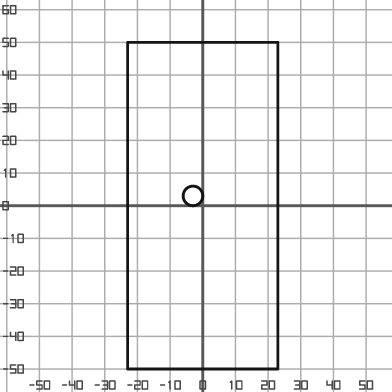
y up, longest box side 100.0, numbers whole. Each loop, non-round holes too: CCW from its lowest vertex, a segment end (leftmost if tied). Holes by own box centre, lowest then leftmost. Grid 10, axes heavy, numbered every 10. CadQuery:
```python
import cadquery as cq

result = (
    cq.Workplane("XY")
    .moveTo(-23.0, -50.0)
    .lineTo(23.0, -50.0)
    .lineTo(23.0, 50.0)
    .lineTo(-23.0, 50.0)
    .close()
    .moveTo(-3.0, 3.0)
    .circle(3.0)
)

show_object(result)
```